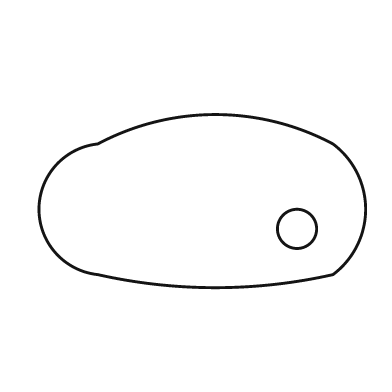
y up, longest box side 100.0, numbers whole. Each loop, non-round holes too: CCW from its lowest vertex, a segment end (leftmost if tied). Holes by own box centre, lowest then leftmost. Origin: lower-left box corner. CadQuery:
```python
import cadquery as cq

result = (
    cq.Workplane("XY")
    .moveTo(18.0, 4.0)
    .threePointArc((54.0, 0.0), (90.0, 4.0))
    .threePointArc((100.0, 24.0), (90.0, 44.0))
    .threePointArc((54.0, 53.0), (18.0, 44.0))
    .threePointArc((0.0, 24.0), (18.0, 4.0))
    .close()
    .moveTo(79.0, 18.0)
    .circle(6.0)
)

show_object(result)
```